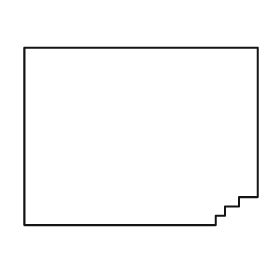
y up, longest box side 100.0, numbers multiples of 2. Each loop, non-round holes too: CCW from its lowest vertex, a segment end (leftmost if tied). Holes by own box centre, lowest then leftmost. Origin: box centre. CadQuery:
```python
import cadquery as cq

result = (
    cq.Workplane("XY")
    .moveTo(-50.0, -38.0)
    .lineTo(32.0, -38.0)
    .lineTo(32.0, -34.0)
    .lineTo(36.0, -34.0)
    .lineTo(36.0, -30.0)
    .lineTo(42.0, -30.0)
    .lineTo(42.0, -26.0)
    .lineTo(50.0, -26.0)
    .lineTo(50.0, 38.0)
    .lineTo(-50.0, 38.0)
    .close()
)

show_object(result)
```